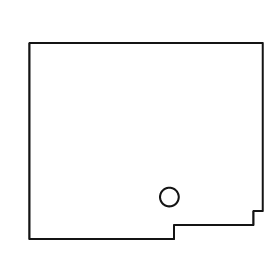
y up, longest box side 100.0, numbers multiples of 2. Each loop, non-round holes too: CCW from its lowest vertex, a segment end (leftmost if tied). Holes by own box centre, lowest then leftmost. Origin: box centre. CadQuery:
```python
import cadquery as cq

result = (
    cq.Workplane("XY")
    .moveTo(-50.0, -42.0)
    .lineTo(12.0, -42.0)
    .lineTo(12.0, -36.0)
    .lineTo(46.0, -36.0)
    .lineTo(46.0, -30.0)
    .lineTo(50.0, -30.0)
    .lineTo(50.0, 42.0)
    .lineTo(-50.0, 42.0)
    .close()
    .moveTo(10.0, -24.0)
    .circle(4.0)
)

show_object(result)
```